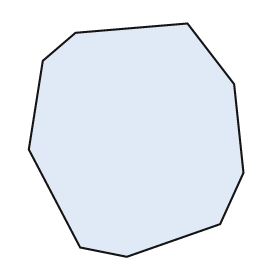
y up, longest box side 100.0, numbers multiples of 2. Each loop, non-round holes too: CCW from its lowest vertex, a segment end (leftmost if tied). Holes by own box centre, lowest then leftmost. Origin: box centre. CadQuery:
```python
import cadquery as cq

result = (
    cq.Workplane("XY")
    .moveTo(-4.0, -50.0)
    .lineTo(36.0, -36.0)
    .lineTo(46.0, -14.0)
    .lineTo(42.0, 24.0)
    .lineTo(22.0, 50.0)
    .lineTo(-26.0, 46.0)
    .lineTo(-40.0, 34.0)
    .lineTo(-46.0, -4.0)
    .lineTo(-24.0, -46.0)
    .close()
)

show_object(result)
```